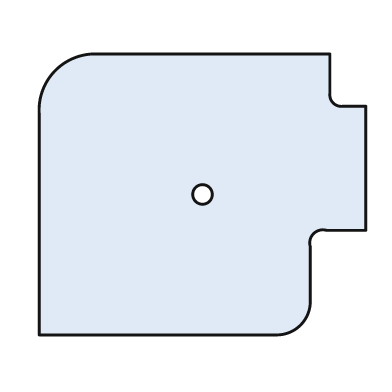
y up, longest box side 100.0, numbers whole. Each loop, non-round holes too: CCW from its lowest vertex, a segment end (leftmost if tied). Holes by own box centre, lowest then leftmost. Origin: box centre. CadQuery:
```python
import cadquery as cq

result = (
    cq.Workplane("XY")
    .moveTo(-50.0, -43.0)
    .lineTo(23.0, -43.0)
    .threePointArc((30.0, -40.0), (33.0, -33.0))
    .lineTo(33.0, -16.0)
    .threePointArc((34.0, -12.0), (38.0, -11.0))
    .lineTo(50.0, -11.0)
    .lineTo(50.0, 27.0)
    .lineTo(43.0, 27.0)
    .threePointArc((40.0, 28.0), (39.0, 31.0))
    .lineTo(39.0, 43.0)
    .lineTo(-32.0, 43.0)
    .threePointArc((-45.0, 38.0), (-50.0, 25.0))
    .close()
    .moveTo(0.0, 0.0)
    .circle(3.0)
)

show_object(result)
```